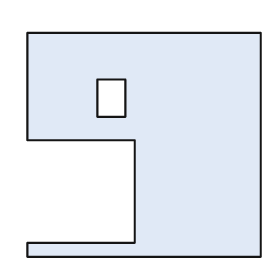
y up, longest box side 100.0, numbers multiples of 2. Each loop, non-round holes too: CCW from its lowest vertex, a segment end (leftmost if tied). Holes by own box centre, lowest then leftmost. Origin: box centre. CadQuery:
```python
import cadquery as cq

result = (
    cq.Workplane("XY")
    .moveTo(-50.0, -48.0)
    .lineTo(50.0, -48.0)
    .lineTo(50.0, 48.0)
    .lineTo(-50.0, 48.0)
    .lineTo(-50.0, 2.0)
    .lineTo(-4.0, 2.0)
    .lineTo(-4.0, -42.0)
    .lineTo(-50.0, -42.0)
    .close()
    .moveTo(-20.0, 12.0)
    .lineTo(-8.0, 12.0)
    .lineTo(-8.0, 28.0)
    .lineTo(-20.0, 28.0)
    .close()
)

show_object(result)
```